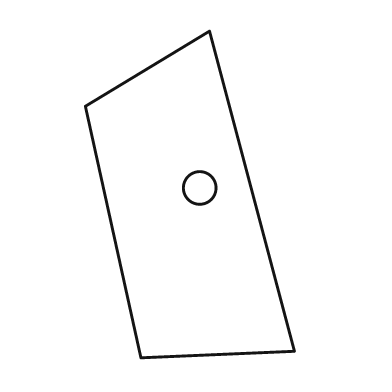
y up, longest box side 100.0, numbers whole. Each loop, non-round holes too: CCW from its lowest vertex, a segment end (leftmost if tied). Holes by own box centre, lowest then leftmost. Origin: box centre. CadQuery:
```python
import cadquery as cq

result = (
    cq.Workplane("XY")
    .moveTo(-15.0, -50.0)
    .lineTo(32.0, -48.0)
    .lineTo(6.0, 50.0)
    .lineTo(-32.0, 27.0)
    .close()
    .moveTo(3.0, 2.0)
    .circle(5.0)
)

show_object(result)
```